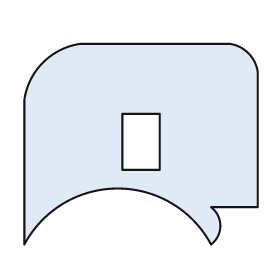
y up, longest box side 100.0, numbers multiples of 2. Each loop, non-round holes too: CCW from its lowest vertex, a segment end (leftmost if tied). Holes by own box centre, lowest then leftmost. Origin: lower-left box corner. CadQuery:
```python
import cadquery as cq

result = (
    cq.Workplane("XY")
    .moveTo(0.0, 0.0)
    .threePointArc((40.0, 24.0), (80.0, 0.0))
    .threePointArc((84.0, 8.0), (80.0, 16.0))
    .lineTo(100.0, 16.0)
    .lineTo(100.0, 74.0)
    .threePointArc((96.0, 82.0), (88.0, 86.0))
    .lineTo(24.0, 86.0)
    .threePointArc((8.0, 78.0), (0.0, 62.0))
    .close()
    .moveTo(42.0, 32.0)
    .lineTo(58.0, 32.0)
    .lineTo(58.0, 56.0)
    .lineTo(42.0, 56.0)
    .close()
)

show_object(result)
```